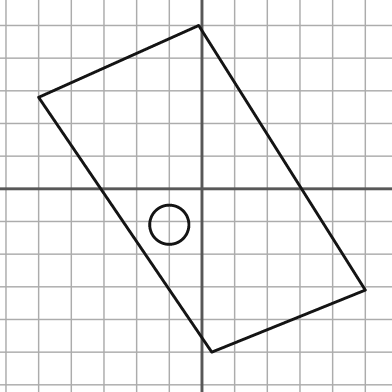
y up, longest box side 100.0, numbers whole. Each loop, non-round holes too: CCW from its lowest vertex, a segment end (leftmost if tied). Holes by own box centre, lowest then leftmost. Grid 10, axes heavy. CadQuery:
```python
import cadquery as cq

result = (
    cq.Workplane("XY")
    .moveTo(3.0, -50.0)
    .lineTo(50.0, -31.0)
    .lineTo(-1.0, 50.0)
    .lineTo(-50.0, 28.0)
    .close()
    .moveTo(-10.0, -11.0)
    .circle(6.0)
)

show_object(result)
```